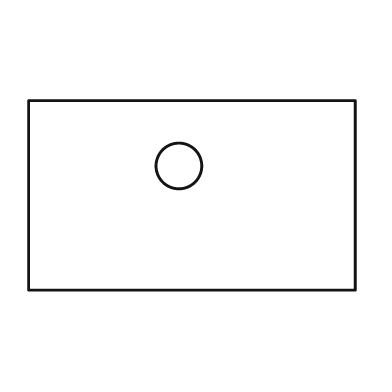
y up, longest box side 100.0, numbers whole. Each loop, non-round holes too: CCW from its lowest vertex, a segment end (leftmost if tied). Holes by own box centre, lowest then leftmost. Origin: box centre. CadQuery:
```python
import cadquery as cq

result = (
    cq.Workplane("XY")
    .moveTo(-50.0, -29.0)
    .lineTo(50.0, -29.0)
    .lineTo(50.0, 29.0)
    .lineTo(-50.0, 29.0)
    .close()
    .moveTo(-4.0, 9.0)
    .circle(7.0)
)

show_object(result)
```